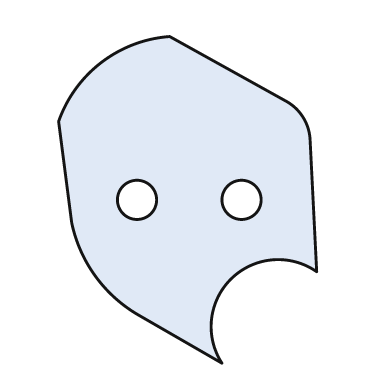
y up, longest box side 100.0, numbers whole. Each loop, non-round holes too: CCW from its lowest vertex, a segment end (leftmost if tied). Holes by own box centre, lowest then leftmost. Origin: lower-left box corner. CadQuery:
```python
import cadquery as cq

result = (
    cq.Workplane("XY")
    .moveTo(50.0, 0.0)
    .threePointArc((53.0, 26.0), (79.0, 28.0))
    .lineTo(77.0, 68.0)
    .threePointArc((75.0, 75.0), (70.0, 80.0))
    .lineTo(34.0, 100.0)
    .threePointArc((13.0, 92.0), (0.0, 74.0))
    .lineTo(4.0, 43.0)
    .threePointArc((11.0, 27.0), (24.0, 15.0))
    .close()
    .moveTo(24.0, 50.0)
    .circle(6.0)
    .moveTo(56.0, 50.0)
    .circle(6.0)
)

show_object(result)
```